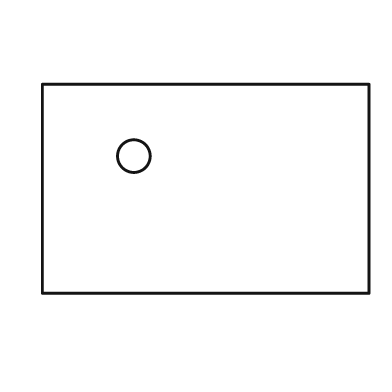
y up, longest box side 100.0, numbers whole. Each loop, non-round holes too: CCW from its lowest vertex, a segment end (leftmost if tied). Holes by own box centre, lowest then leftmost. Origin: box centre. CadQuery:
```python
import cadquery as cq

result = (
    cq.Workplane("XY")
    .moveTo(-50.0, -32.0)
    .lineTo(50.0, -32.0)
    .lineTo(50.0, 32.0)
    .lineTo(-50.0, 32.0)
    .close()
    .moveTo(-22.0, 10.0)
    .circle(5.0)
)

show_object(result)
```